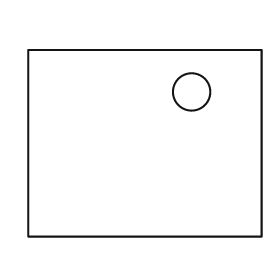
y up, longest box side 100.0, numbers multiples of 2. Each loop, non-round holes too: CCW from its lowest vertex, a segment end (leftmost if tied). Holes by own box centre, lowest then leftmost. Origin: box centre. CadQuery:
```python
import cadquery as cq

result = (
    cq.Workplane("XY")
    .moveTo(-50.0, -40.0)
    .lineTo(50.0, -40.0)
    .lineTo(50.0, 40.0)
    .lineTo(-50.0, 40.0)
    .close()
    .moveTo(20.0, 22.0)
    .circle(8.0)
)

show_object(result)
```